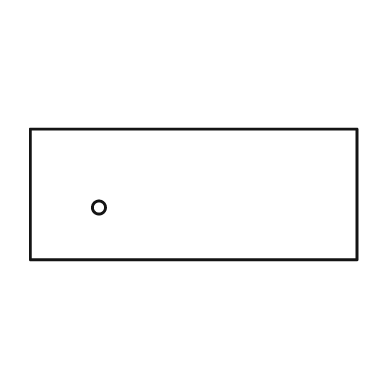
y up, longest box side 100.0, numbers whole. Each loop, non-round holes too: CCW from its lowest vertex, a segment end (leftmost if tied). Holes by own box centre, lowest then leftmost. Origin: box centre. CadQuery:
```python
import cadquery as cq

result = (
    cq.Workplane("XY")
    .moveTo(-50.0, -20.0)
    .lineTo(50.0, -20.0)
    .lineTo(50.0, 20.0)
    .lineTo(-50.0, 20.0)
    .close()
    .moveTo(-29.0, -4.0)
    .circle(2.0)
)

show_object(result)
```